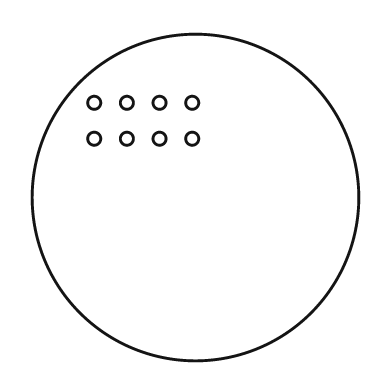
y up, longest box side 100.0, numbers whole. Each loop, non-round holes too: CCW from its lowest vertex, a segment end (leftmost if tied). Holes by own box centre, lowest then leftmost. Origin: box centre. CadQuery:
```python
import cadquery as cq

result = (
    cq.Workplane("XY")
    .moveTo(0.0, 0.0)
    .circle(50.0)
    .moveTo(-31.0, 18.0)
    .circle(2.0)
    .moveTo(-21.0, 18.0)
    .circle(2.0)
    .moveTo(-11.0, 18.0)
    .circle(2.0)
    .moveTo(-1.0, 18.0)
    .circle(2.0)
    .moveTo(-31.0, 29.0)
    .circle(2.0)
    .moveTo(-21.0, 29.0)
    .circle(2.0)
    .moveTo(-11.0, 29.0)
    .circle(2.0)
    .moveTo(-1.0, 29.0)
    .circle(2.0)
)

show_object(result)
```